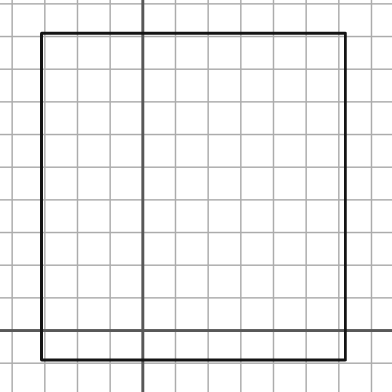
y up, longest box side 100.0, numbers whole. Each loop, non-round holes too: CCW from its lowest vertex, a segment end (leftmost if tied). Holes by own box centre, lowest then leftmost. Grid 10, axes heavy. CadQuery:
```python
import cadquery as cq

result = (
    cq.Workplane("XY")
    .moveTo(-31.0, -9.0)
    .lineTo(62.0, -9.0)
    .lineTo(62.0, 91.0)
    .lineTo(-31.0, 91.0)
    .close()
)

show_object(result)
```